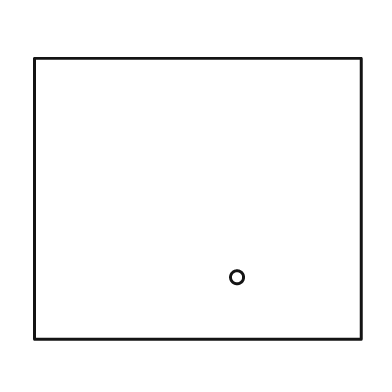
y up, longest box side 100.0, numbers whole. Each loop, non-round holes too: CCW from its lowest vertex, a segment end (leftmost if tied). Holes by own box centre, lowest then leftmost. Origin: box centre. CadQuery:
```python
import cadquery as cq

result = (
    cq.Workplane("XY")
    .moveTo(-50.0, -43.0)
    .lineTo(50.0, -43.0)
    .lineTo(50.0, 43.0)
    .lineTo(-50.0, 43.0)
    .close()
    .moveTo(12.0, -24.0)
    .circle(2.0)
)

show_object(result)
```